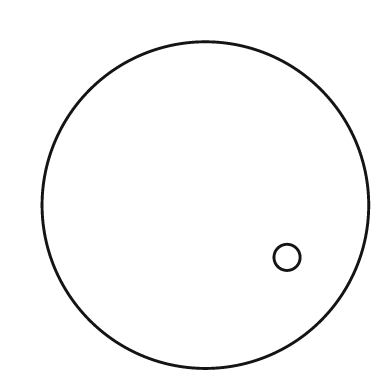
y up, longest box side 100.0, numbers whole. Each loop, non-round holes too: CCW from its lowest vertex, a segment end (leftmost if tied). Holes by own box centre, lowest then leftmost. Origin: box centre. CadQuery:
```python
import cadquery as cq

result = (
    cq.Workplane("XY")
    .moveTo(0.0, 0.0)
    .circle(50.0)
    .moveTo(25.0, -16.0)
    .circle(4.0)
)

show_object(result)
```